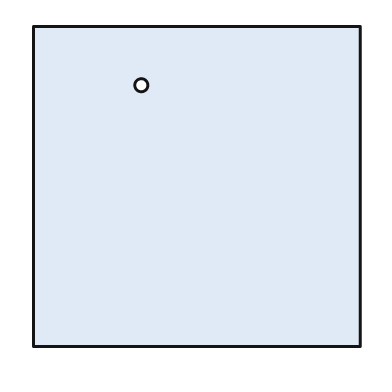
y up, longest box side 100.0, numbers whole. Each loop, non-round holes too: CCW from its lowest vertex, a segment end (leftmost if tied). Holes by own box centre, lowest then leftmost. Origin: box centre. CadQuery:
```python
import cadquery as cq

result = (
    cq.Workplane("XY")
    .moveTo(-50.0, -49.0)
    .lineTo(50.0, -49.0)
    .lineTo(50.0, 49.0)
    .lineTo(-50.0, 49.0)
    .close()
    .moveTo(-17.0, 31.0)
    .circle(2.0)
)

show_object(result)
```